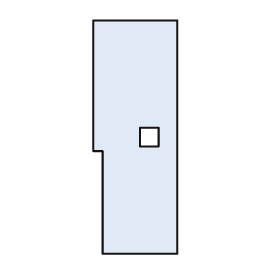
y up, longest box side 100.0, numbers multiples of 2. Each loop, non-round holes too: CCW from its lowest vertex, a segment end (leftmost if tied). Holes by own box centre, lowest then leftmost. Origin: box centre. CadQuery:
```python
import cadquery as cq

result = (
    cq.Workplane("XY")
    .moveTo(-14.0, -50.0)
    .lineTo(18.0, -50.0)
    .lineTo(18.0, 50.0)
    .lineTo(-18.0, 50.0)
    .lineTo(-18.0, -6.0)
    .lineTo(-14.0, -6.0)
    .close()
    .moveTo(2.0, -4.0)
    .lineTo(10.0, -4.0)
    .lineTo(10.0, 4.0)
    .lineTo(2.0, 4.0)
    .close()
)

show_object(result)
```